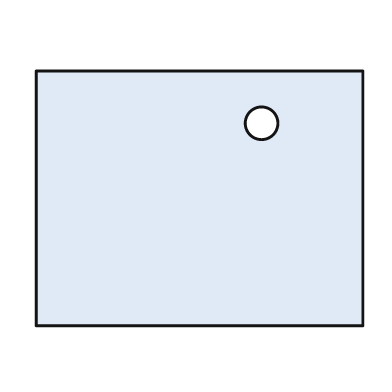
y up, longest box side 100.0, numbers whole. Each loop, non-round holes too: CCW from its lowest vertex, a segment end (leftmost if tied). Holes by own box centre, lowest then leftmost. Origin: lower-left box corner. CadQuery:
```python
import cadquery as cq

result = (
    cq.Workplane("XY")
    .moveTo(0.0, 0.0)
    .lineTo(100.0, 0.0)
    .lineTo(100.0, 78.0)
    .lineTo(0.0, 78.0)
    .close()
    .moveTo(69.0, 62.0)
    .circle(5.0)
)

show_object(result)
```